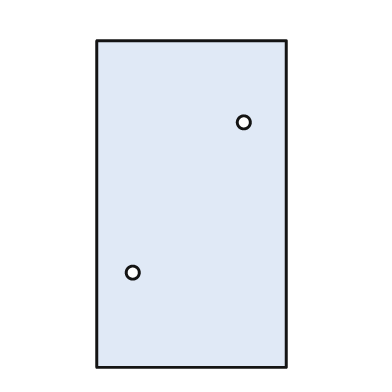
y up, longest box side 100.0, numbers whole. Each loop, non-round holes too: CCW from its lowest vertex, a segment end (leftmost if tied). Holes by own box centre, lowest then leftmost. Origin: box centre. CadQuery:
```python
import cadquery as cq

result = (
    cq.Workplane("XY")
    .moveTo(-29.0, -50.0)
    .lineTo(29.0, -50.0)
    .lineTo(29.0, 50.0)
    .lineTo(-29.0, 50.0)
    .close()
    .moveTo(-18.0, -21.0)
    .circle(2.0)
    .moveTo(16.0, 25.0)
    .circle(2.0)
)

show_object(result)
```